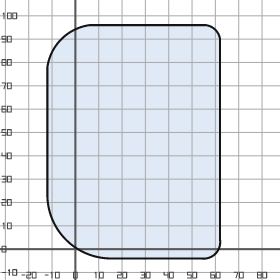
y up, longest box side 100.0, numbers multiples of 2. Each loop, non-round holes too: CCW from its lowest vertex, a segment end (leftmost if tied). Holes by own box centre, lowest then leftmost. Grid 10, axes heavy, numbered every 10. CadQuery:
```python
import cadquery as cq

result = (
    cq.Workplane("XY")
    .moveTo(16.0, -4.0)
    .lineTo(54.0, -4.0)
    .threePointArc((60.0, -2.0), (62.0, 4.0))
    .lineTo(62.0, 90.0)
    .threePointArc((60.0, 94.0), (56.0, 96.0))
    .lineTo(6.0, 96.0)
    .threePointArc((-6.0, 90.0), (-12.0, 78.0))
    .lineTo(-12.0, 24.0)
    .threePointArc((-4.0, 4.0), (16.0, -4.0))
    .close()
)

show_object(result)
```